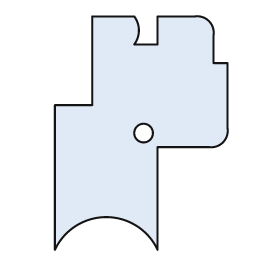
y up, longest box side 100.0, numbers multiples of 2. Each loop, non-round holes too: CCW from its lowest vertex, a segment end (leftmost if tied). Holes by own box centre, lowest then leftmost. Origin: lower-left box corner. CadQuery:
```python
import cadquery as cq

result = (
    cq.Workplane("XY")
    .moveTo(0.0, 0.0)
    .threePointArc((22.0, 14.0), (44.0, 0.0))
    .lineTo(44.0, 44.0)
    .lineTo(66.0, 44.0)
    .threePointArc((72.0, 46.0), (74.0, 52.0))
    .lineTo(74.0, 80.0)
    .lineTo(68.0, 80.0)
    .lineTo(68.0, 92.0)
    .threePointArc((66.0, 98.0), (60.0, 100.0))
    .lineTo(44.0, 100.0)
    .lineTo(44.0, 88.0)
    .lineTo(34.0, 88.0)
    .threePointArc((36.0, 94.0), (34.0, 100.0))
    .lineTo(16.0, 100.0)
    .lineTo(16.0, 62.0)
    .lineTo(0.0, 62.0)
    .close()
    .moveTo(38.0, 50.0)
    .circle(4.0)
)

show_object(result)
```